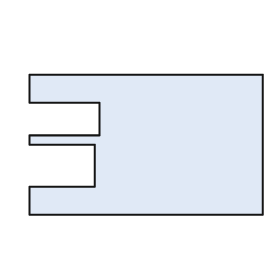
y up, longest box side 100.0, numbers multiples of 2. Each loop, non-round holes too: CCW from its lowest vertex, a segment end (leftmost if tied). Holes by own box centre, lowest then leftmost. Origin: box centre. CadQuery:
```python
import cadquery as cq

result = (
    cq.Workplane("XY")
    .moveTo(-50.0, -30.0)
    .lineTo(50.0, -30.0)
    .lineTo(50.0, 30.0)
    .lineTo(-50.0, 30.0)
    .lineTo(-50.0, 18.0)
    .lineTo(-20.0, 18.0)
    .lineTo(-20.0, 4.0)
    .lineTo(-50.0, 4.0)
    .lineTo(-50.0, 0.0)
    .lineTo(-22.0, 0.0)
    .lineTo(-22.0, -18.0)
    .lineTo(-50.0, -18.0)
    .close()
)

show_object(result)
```